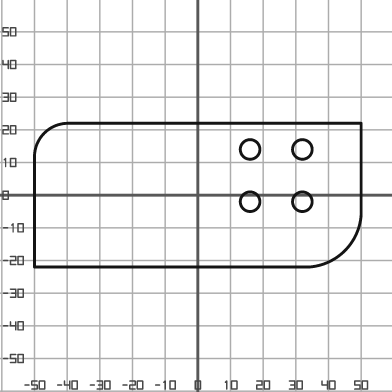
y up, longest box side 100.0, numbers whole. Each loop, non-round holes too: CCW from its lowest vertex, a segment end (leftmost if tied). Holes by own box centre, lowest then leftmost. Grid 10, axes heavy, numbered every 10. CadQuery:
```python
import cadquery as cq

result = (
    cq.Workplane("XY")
    .moveTo(-50.0, -22.0)
    .lineTo(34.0, -22.0)
    .threePointArc((45.0, -17.0), (50.0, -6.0))
    .lineTo(50.0, 22.0)
    .lineTo(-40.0, 22.0)
    .threePointArc((-47.0, 19.0), (-50.0, 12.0))
    .close()
    .moveTo(16.0, -2.0)
    .circle(3.0)
    .moveTo(32.0, -2.0)
    .circle(3.0)
    .moveTo(16.0, 14.0)
    .circle(3.0)
    .moveTo(32.0, 14.0)
    .circle(3.0)
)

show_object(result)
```